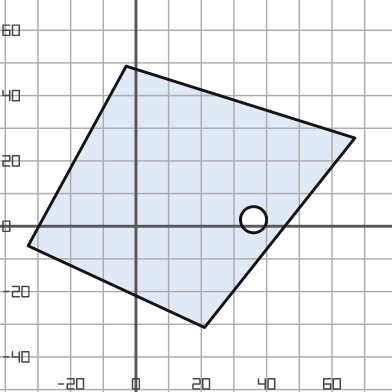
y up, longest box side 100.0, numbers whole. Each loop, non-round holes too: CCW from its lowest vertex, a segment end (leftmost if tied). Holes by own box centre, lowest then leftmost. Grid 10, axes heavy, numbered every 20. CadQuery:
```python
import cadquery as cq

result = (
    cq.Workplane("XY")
    .moveTo(21.0, -31.0)
    .lineTo(67.0, 27.0)
    .lineTo(-3.0, 49.0)
    .lineTo(-33.0, -6.0)
    .close()
    .moveTo(36.0, 2.0)
    .circle(4.0)
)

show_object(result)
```